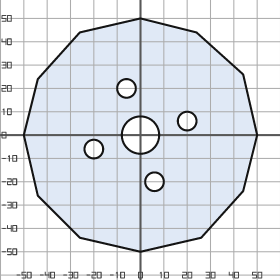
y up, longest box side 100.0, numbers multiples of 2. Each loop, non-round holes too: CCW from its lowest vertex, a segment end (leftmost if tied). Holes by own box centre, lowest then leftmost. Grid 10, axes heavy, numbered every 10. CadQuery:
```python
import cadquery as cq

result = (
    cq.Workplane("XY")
    .moveTo(0.0, -50.0)
    .lineTo(26.0, -44.0)
    .lineTo(44.0, -24.0)
    .lineTo(50.0, 0.0)
    .lineTo(44.0, 26.0)
    .lineTo(24.0, 44.0)
    .lineTo(0.0, 50.0)
    .lineTo(-26.0, 44.0)
    .lineTo(-44.0, 24.0)
    .lineTo(-50.0, 0.0)
    .lineTo(-44.0, -26.0)
    .lineTo(-26.0, -44.0)
    .close()
    .moveTo(6.0, -20.0)
    .circle(4.0)
    .moveTo(-20.0, -6.0)
    .circle(4.0)
    .moveTo(0.0, 0.0)
    .circle(8.0)
    .moveTo(20.0, 6.0)
    .circle(4.0)
    .moveTo(-6.0, 20.0)
    .circle(4.0)
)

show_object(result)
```